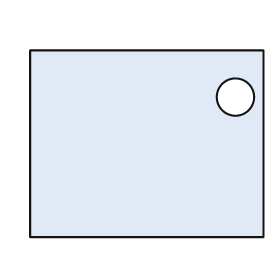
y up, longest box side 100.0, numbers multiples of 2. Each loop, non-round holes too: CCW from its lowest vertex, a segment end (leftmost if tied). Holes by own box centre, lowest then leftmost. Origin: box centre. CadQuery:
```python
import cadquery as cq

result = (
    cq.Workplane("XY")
    .moveTo(-50.0, -40.0)
    .lineTo(50.0, -40.0)
    .lineTo(50.0, 40.0)
    .lineTo(-50.0, 40.0)
    .close()
    .moveTo(38.0, 20.0)
    .circle(8.0)
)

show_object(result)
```